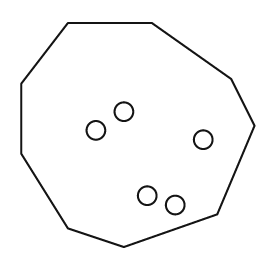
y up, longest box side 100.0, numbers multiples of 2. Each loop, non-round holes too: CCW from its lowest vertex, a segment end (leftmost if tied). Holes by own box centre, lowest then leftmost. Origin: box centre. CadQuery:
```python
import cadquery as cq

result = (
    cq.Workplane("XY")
    .moveTo(-6.0, -48.0)
    .lineTo(34.0, -34.0)
    .lineTo(50.0, 4.0)
    .lineTo(40.0, 24.0)
    .lineTo(6.0, 48.0)
    .lineTo(-30.0, 48.0)
    .lineTo(-50.0, 22.0)
    .lineTo(-50.0, -8.0)
    .lineTo(-30.0, -40.0)
    .close()
    .moveTo(16.0, -30.0)
    .circle(4.0)
    .moveTo(4.0, -26.0)
    .circle(4.0)
    .moveTo(28.0, -2.0)
    .circle(4.0)
    .moveTo(-18.0, 2.0)
    .circle(4.0)
    .moveTo(-6.0, 10.0)
    .circle(4.0)
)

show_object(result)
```